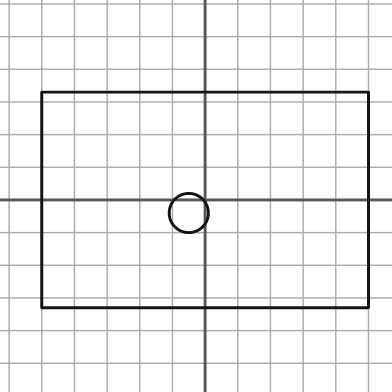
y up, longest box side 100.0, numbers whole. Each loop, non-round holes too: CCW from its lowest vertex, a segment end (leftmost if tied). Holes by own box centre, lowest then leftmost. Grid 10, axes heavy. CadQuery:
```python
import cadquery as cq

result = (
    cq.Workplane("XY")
    .moveTo(-50.0, -33.0)
    .lineTo(50.0, -33.0)
    .lineTo(50.0, 33.0)
    .lineTo(-50.0, 33.0)
    .close()
    .moveTo(-5.0, -4.0)
    .circle(6.0)
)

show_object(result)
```